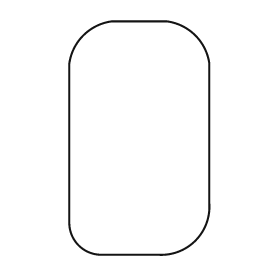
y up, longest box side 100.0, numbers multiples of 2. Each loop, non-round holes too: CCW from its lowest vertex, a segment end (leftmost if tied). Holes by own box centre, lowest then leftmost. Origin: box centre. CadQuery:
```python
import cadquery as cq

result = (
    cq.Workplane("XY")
    .moveTo(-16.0, -50.0)
    .lineTo(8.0, -50.0)
    .threePointArc((24.0, -44.0), (30.0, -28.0))
    .lineTo(30.0, 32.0)
    .threePointArc((24.0, 44.0), (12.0, 50.0))
    .lineTo(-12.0, 50.0)
    .threePointArc((-24.0, 44.0), (-30.0, 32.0))
    .lineTo(-30.0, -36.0)
    .threePointArc((-26.0, -46.0), (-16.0, -50.0))
    .close()
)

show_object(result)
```